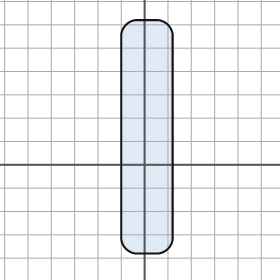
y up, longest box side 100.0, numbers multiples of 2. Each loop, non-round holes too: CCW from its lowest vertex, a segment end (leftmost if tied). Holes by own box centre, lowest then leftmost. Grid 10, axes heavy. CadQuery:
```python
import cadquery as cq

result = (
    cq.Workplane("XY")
    .moveTo(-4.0, -38.0)
    .lineTo(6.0, -38.0)
    .threePointArc((10.0, -36.0), (12.0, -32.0))
    .lineTo(12.0, 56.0)
    .threePointArc((10.0, 60.0), (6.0, 62.0))
    .lineTo(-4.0, 62.0)
    .threePointArc((-8.0, 60.0), (-10.0, 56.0))
    .lineTo(-10.0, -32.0)
    .threePointArc((-8.0, -36.0), (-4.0, -38.0))
    .close()
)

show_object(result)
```